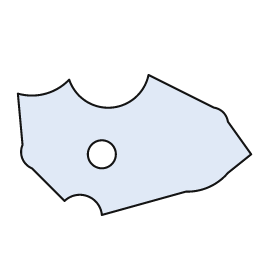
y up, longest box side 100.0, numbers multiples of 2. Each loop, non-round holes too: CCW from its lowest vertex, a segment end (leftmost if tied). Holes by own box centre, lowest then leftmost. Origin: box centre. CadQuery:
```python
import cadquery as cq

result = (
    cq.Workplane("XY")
    .moveTo(-14.0, -30.0)
    .lineTo(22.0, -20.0)
    .threePointArc((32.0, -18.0), (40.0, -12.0))
    .lineTo(50.0, -4.0)
    .lineTo(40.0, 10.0)
    .threePointArc((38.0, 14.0), (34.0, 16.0))
    .lineTo(6.0, 30.0)
    .threePointArc((-10.0, 16.0), (-28.0, 28.0))
    .threePointArc((-38.0, 22.0), (-50.0, 22.0))
    .lineTo(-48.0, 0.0)
    .threePointArc((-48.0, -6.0), (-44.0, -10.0))
    .lineTo(-30.0, -24.0)
    .threePointArc((-20.0, -22.0), (-14.0, -30.0))
    .close()
    .moveTo(-14.0, -4.0)
    .circle(6.0)
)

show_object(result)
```